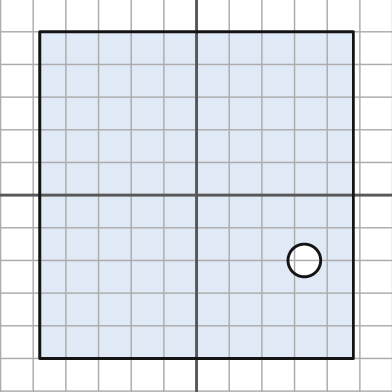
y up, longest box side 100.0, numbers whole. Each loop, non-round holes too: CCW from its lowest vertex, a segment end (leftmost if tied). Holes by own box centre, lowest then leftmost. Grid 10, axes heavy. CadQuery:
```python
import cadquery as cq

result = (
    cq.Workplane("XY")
    .moveTo(-48.0, -50.0)
    .lineTo(48.0, -50.0)
    .lineTo(48.0, 50.0)
    .lineTo(-48.0, 50.0)
    .close()
    .moveTo(33.0, -20.0)
    .circle(5.0)
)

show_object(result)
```